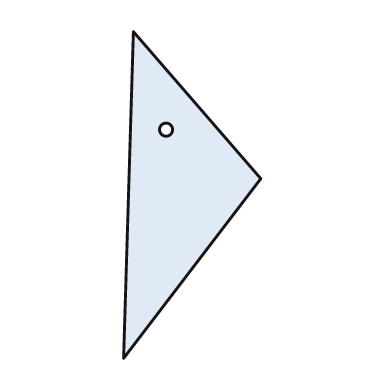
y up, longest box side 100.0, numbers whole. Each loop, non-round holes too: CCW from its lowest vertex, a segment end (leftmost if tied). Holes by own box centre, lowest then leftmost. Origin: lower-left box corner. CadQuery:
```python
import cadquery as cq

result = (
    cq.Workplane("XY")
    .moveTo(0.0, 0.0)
    .lineTo(42.0, 55.0)
    .lineTo(3.0, 100.0)
    .close()
    .moveTo(13.0, 70.0)
    .circle(2.0)
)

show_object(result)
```